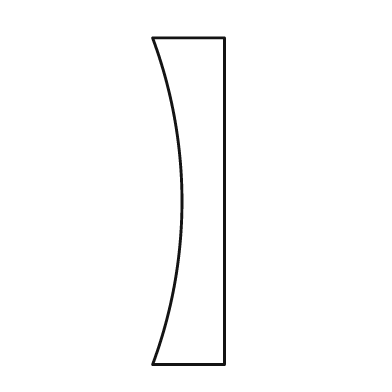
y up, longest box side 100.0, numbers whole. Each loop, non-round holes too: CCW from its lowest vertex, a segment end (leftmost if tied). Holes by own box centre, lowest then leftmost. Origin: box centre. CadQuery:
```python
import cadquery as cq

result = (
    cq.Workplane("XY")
    .moveTo(-11.0, -50.0)
    .lineTo(11.0, -50.0)
    .lineTo(11.0, 50.0)
    .lineTo(-11.0, 50.0)
    .threePointArc((-2.0, 0.0), (-11.0, -50.0))
    .close()
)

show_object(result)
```